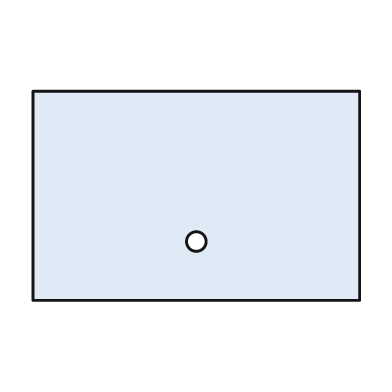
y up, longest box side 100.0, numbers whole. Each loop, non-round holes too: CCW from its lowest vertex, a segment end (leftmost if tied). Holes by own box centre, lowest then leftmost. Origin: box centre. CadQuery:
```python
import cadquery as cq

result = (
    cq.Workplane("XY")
    .moveTo(-50.0, -32.0)
    .lineTo(50.0, -32.0)
    .lineTo(50.0, 32.0)
    .lineTo(-50.0, 32.0)
    .close()
    .moveTo(0.0, -14.0)
    .circle(3.0)
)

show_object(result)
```